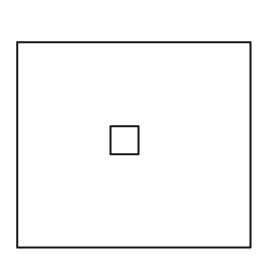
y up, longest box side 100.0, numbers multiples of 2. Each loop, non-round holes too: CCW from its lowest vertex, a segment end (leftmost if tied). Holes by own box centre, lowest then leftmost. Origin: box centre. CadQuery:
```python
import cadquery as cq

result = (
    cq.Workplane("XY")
    .moveTo(-50.0, -44.0)
    .lineTo(50.0, -44.0)
    .lineTo(50.0, 44.0)
    .lineTo(-50.0, 44.0)
    .close()
    .moveTo(-10.0, -4.0)
    .lineTo(2.0, -4.0)
    .lineTo(2.0, 8.0)
    .lineTo(-10.0, 8.0)
    .close()
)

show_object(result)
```